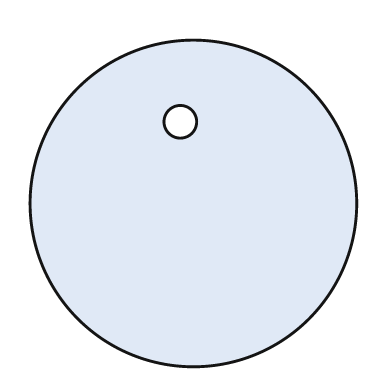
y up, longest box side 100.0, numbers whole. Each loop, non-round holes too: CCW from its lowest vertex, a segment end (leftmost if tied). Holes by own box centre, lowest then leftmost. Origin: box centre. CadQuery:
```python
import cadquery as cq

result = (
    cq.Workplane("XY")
    .moveTo(0.0, 0.0)
    .circle(50.0)
    .moveTo(-4.0, 25.0)
    .circle(5.0)
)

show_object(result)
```